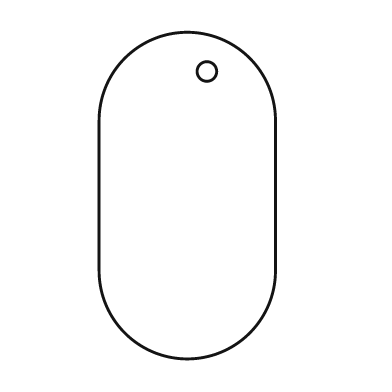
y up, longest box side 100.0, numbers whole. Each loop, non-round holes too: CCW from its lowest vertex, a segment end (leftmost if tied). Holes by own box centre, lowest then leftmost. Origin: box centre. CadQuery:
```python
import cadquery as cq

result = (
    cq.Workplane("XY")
    .moveTo(-27.0, -23.0)
    .threePointArc((0.0, -50.0), (27.0, -23.0))
    .lineTo(27.0, 23.0)
    .threePointArc((0.0, 50.0), (-27.0, 23.0))
    .close()
    .moveTo(6.0, 38.0)
    .circle(3.0)
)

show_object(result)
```